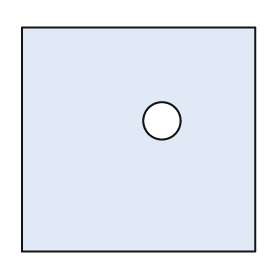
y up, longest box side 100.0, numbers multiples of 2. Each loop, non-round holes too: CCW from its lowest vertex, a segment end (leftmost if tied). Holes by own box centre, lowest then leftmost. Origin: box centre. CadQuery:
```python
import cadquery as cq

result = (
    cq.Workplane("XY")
    .moveTo(-50.0, -48.0)
    .lineTo(50.0, -48.0)
    .lineTo(50.0, 48.0)
    .lineTo(-50.0, 48.0)
    .close()
    .moveTo(10.0, 8.0)
    .circle(8.0)
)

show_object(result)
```